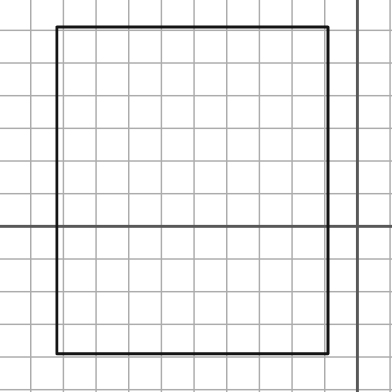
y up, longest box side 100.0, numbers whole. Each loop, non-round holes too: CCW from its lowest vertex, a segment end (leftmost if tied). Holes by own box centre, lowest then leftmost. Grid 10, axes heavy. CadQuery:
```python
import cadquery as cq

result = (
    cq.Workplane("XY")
    .moveTo(-92.0, -39.0)
    .lineTo(-9.0, -39.0)
    .lineTo(-9.0, 61.0)
    .lineTo(-92.0, 61.0)
    .close()
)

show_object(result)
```